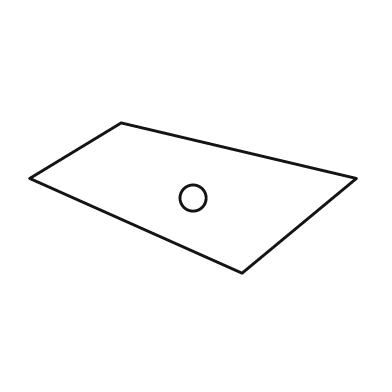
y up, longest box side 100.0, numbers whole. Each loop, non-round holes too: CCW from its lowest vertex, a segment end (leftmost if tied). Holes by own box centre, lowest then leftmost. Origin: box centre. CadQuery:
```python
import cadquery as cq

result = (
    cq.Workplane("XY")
    .moveTo(15.0, -23.0)
    .lineTo(50.0, 6.0)
    .lineTo(-22.0, 23.0)
    .lineTo(-50.0, 6.0)
    .close()
    .moveTo(0.0, 0.0)
    .circle(4.0)
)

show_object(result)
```